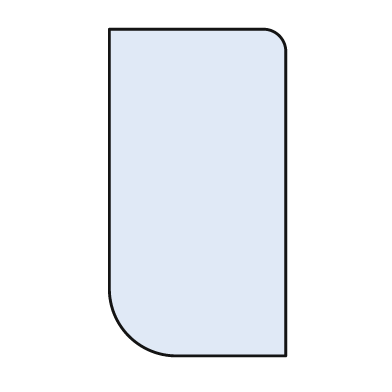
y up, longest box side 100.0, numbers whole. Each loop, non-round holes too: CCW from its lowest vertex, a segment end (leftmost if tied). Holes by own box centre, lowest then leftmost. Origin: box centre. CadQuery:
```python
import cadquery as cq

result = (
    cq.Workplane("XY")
    .moveTo(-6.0, -50.0)
    .lineTo(27.0, -50.0)
    .lineTo(27.0, 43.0)
    .threePointArc((25.0, 48.0), (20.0, 50.0))
    .lineTo(-27.0, 50.0)
    .lineTo(-27.0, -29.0)
    .threePointArc((-21.0, -44.0), (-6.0, -50.0))
    .close()
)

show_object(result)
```